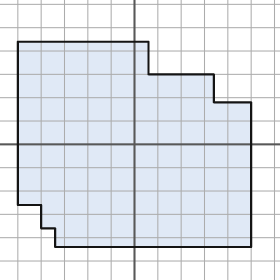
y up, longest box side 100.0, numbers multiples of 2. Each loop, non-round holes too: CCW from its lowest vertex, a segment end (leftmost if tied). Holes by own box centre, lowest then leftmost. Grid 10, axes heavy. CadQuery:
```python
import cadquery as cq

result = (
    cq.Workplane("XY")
    .moveTo(-34.0, -44.0)
    .lineTo(50.0, -44.0)
    .lineTo(50.0, 18.0)
    .lineTo(34.0, 18.0)
    .lineTo(34.0, 30.0)
    .lineTo(6.0, 30.0)
    .lineTo(6.0, 44.0)
    .lineTo(-50.0, 44.0)
    .lineTo(-50.0, -26.0)
    .lineTo(-40.0, -26.0)
    .lineTo(-40.0, -36.0)
    .lineTo(-34.0, -36.0)
    .close()
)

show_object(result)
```